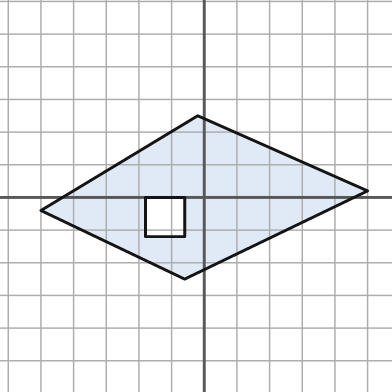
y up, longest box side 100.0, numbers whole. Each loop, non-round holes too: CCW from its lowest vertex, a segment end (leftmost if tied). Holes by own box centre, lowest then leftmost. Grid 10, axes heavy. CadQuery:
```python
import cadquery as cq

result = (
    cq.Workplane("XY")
    .moveTo(-6.0, -25.0)
    .lineTo(50.0, 2.0)
    .lineTo(-2.0, 25.0)
    .lineTo(-50.0, -4.0)
    .close()
    .moveTo(-18.0, -12.0)
    .lineTo(-6.0, -12.0)
    .lineTo(-6.0, 0.0)
    .lineTo(-18.0, 0.0)
    .close()
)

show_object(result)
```